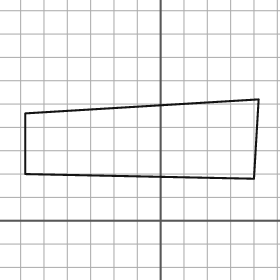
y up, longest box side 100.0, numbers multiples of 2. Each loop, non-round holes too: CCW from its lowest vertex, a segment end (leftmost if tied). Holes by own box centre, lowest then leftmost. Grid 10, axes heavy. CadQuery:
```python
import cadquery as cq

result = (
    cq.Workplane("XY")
    .moveTo(40.0, 18.0)
    .lineTo(42.0, 52.0)
    .lineTo(-58.0, 46.0)
    .lineTo(-58.0, 20.0)
    .close()
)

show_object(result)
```